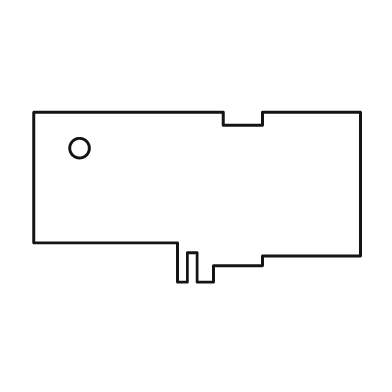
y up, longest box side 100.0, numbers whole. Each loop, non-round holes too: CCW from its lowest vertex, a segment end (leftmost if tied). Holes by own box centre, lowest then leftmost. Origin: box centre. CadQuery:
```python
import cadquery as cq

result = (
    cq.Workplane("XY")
    .moveTo(-6.0, -26.0)
    .lineTo(-3.0, -26.0)
    .lineTo(-3.0, -17.0)
    .lineTo(0.0, -17.0)
    .lineTo(0.0, -26.0)
    .lineTo(5.0, -26.0)
    .lineTo(5.0, -21.0)
    .lineTo(20.0, -21.0)
    .lineTo(20.0, -18.0)
    .lineTo(50.0, -18.0)
    .lineTo(50.0, 26.0)
    .lineTo(20.0, 26.0)
    .lineTo(20.0, 22.0)
    .lineTo(8.0, 22.0)
    .lineTo(8.0, 26.0)
    .lineTo(-50.0, 26.0)
    .lineTo(-50.0, -14.0)
    .lineTo(-6.0, -14.0)
    .close()
    .moveTo(-36.0, 15.0)
    .circle(3.0)
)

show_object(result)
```